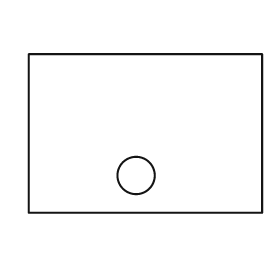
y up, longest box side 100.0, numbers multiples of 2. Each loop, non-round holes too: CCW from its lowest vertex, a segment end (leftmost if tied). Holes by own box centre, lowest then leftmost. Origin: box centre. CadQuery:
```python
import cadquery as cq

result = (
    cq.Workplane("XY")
    .moveTo(-50.0, -34.0)
    .lineTo(50.0, -34.0)
    .lineTo(50.0, 34.0)
    .lineTo(-50.0, 34.0)
    .close()
    .moveTo(-4.0, -18.0)
    .circle(8.0)
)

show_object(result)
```